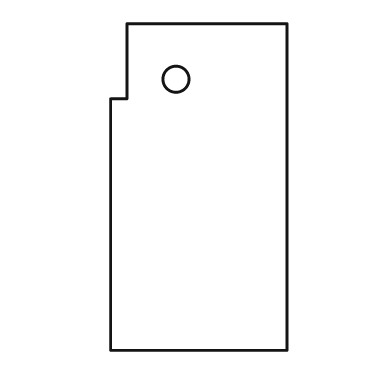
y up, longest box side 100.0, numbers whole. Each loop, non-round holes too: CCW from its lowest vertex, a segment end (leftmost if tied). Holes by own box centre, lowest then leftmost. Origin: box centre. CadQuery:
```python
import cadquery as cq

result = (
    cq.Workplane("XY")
    .moveTo(-27.0, -50.0)
    .lineTo(27.0, -50.0)
    .lineTo(27.0, 50.0)
    .lineTo(-22.0, 50.0)
    .lineTo(-22.0, 27.0)
    .lineTo(-27.0, 27.0)
    .close()
    .moveTo(-7.0, 33.0)
    .circle(4.0)
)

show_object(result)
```